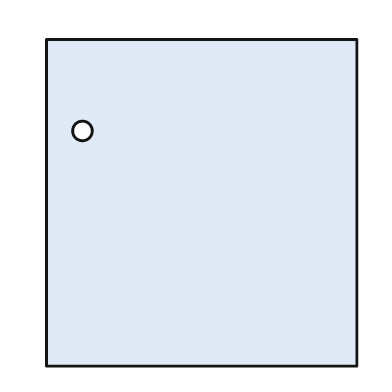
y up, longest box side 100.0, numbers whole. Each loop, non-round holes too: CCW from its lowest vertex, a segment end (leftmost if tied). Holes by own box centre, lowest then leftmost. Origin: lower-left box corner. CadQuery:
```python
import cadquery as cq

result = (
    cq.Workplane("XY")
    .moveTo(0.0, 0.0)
    .lineTo(95.0, 0.0)
    .lineTo(95.0, 100.0)
    .lineTo(0.0, 100.0)
    .close()
    .moveTo(11.0, 72.0)
    .circle(3.0)
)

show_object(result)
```